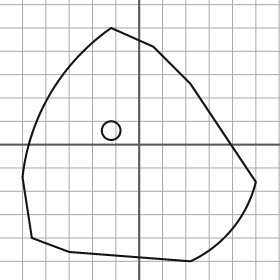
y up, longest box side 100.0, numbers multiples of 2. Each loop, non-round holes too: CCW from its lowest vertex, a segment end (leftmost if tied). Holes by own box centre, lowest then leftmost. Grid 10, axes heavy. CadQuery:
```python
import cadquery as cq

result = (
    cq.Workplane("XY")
    .moveTo(22.0, -50.0)
    .threePointArc((40.0, -36.0), (50.0, -16.0))
    .lineTo(22.0, 26.0)
    .lineTo(6.0, 42.0)
    .lineTo(-12.0, 50.0)
    .threePointArc((-38.0, 22.0), (-50.0, -14.0))
    .lineTo(-46.0, -40.0)
    .lineTo(-30.0, -46.0)
    .close()
    .moveTo(-12.0, 6.0)
    .circle(4.0)
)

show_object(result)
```